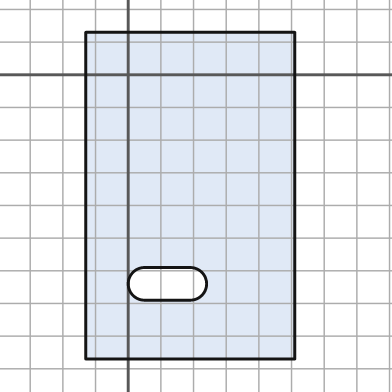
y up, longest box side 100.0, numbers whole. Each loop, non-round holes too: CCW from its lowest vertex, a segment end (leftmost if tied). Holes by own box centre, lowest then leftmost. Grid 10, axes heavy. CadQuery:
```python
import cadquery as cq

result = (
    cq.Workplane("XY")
    .moveTo(-13.0, -87.0)
    .lineTo(51.0, -87.0)
    .lineTo(51.0, 13.0)
    .lineTo(-13.0, 13.0)
    .close()
    .moveTo(5.0, -69.0)
    .lineTo(19.0, -69.0)
    .threePointArc((24.0, -64.0), (19.0, -59.0))
    .lineTo(5.0, -59.0)
    .threePointArc((0.0, -64.0), (5.0, -69.0))
    .close()
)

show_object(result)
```